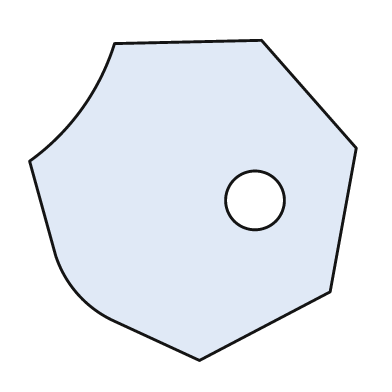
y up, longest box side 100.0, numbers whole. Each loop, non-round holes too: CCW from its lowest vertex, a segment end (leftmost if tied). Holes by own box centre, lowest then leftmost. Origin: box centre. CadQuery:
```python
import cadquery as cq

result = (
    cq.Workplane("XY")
    .moveTo(2.0, -49.0)
    .lineTo(42.0, -28.0)
    .lineTo(50.0, 16.0)
    .lineTo(21.0, 49.0)
    .lineTo(-24.0, 48.0)
    .threePointArc((-34.0, 28.0), (-50.0, 12.0))
    .lineTo(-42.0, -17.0)
    .threePointArc((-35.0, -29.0), (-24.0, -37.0))
    .close()
    .moveTo(19.0, 0.0)
    .circle(9.0)
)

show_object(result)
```